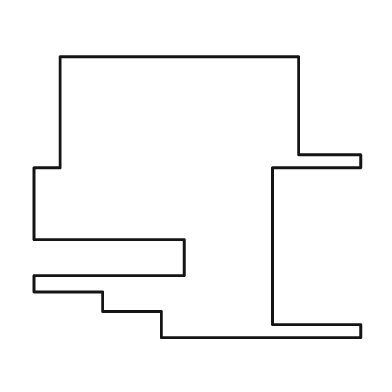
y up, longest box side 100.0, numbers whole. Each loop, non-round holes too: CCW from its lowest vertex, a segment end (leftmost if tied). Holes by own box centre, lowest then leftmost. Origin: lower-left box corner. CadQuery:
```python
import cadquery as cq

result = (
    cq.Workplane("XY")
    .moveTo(39.0, 0.0)
    .lineTo(100.0, 0.0)
    .lineTo(100.0, 4.0)
    .lineTo(73.0, 4.0)
    .lineTo(73.0, 52.0)
    .lineTo(100.0, 52.0)
    .lineTo(100.0, 56.0)
    .lineTo(81.0, 56.0)
    .lineTo(81.0, 86.0)
    .lineTo(8.0, 86.0)
    .lineTo(8.0, 52.0)
    .lineTo(0.0, 52.0)
    .lineTo(0.0, 30.0)
    .lineTo(46.0, 30.0)
    .lineTo(46.0, 19.0)
    .lineTo(0.0, 19.0)
    .lineTo(0.0, 14.0)
    .lineTo(21.0, 14.0)
    .lineTo(21.0, 8.0)
    .lineTo(39.0, 8.0)
    .close()
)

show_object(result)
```